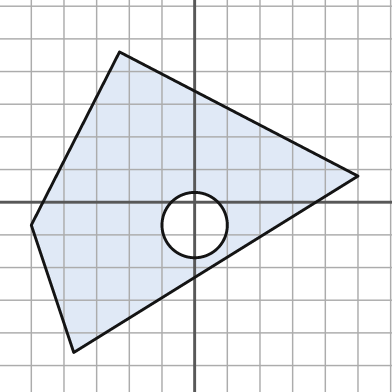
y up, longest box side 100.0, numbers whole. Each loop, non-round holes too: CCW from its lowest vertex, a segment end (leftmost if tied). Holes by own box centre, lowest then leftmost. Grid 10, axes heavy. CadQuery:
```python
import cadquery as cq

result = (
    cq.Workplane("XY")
    .moveTo(-37.0, -46.0)
    .lineTo(50.0, 8.0)
    .lineTo(-23.0, 46.0)
    .lineTo(-50.0, -7.0)
    .close()
    .moveTo(0.0, -7.0)
    .circle(10.0)
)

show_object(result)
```